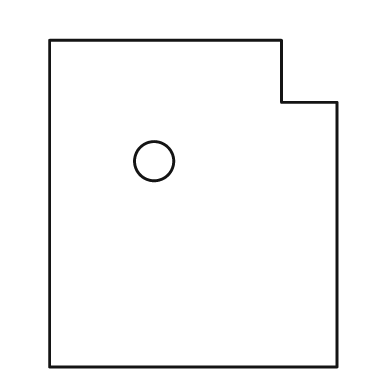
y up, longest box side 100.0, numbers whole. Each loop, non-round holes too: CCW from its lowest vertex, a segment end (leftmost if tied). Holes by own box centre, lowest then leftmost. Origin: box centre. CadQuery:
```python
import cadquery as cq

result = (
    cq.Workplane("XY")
    .moveTo(-44.0, -50.0)
    .lineTo(44.0, -50.0)
    .lineTo(44.0, 31.0)
    .lineTo(27.0, 31.0)
    .lineTo(27.0, 50.0)
    .lineTo(-44.0, 50.0)
    .close()
    .moveTo(-12.0, 13.0)
    .circle(6.0)
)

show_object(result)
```